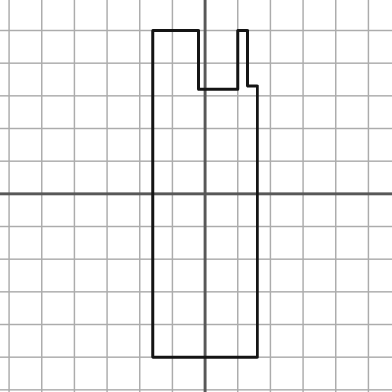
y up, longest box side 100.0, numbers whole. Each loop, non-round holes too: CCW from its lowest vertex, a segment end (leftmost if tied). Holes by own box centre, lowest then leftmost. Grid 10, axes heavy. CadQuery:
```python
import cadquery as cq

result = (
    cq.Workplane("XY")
    .moveTo(-16.0, -50.0)
    .lineTo(16.0, -50.0)
    .lineTo(16.0, 33.0)
    .lineTo(13.0, 33.0)
    .lineTo(13.0, 50.0)
    .lineTo(10.0, 50.0)
    .lineTo(10.0, 32.0)
    .lineTo(-2.0, 32.0)
    .lineTo(-2.0, 50.0)
    .lineTo(-16.0, 50.0)
    .close()
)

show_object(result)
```